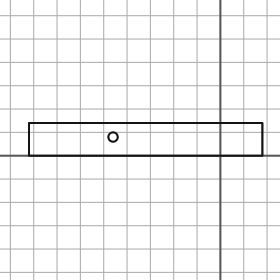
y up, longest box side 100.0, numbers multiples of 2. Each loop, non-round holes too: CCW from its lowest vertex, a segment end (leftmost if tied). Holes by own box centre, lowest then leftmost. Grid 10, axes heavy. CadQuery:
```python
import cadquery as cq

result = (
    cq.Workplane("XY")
    .moveTo(-82.0, 0.0)
    .lineTo(18.0, 0.0)
    .lineTo(18.0, 14.0)
    .lineTo(-82.0, 14.0)
    .close()
    .moveTo(-46.0, 8.0)
    .circle(2.0)
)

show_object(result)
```